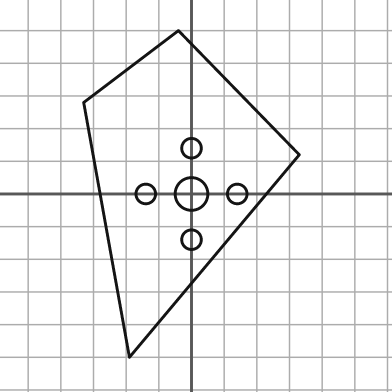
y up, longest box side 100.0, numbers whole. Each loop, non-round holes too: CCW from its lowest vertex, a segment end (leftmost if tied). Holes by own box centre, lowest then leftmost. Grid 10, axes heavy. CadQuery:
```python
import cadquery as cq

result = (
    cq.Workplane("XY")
    .moveTo(-19.0, -50.0)
    .lineTo(33.0, 12.0)
    .lineTo(-4.0, 50.0)
    .lineTo(-33.0, 28.0)
    .close()
    .moveTo(0.0, -14.0)
    .circle(3.0)
    .moveTo(-14.0, 0.0)
    .circle(3.0)
    .moveTo(0.0, 0.0)
    .circle(5.0)
    .moveTo(14.0, 0.0)
    .circle(3.0)
    .moveTo(0.0, 14.0)
    .circle(3.0)
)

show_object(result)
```